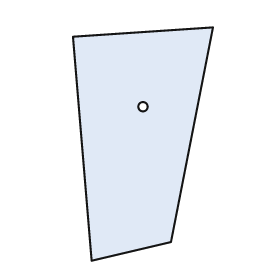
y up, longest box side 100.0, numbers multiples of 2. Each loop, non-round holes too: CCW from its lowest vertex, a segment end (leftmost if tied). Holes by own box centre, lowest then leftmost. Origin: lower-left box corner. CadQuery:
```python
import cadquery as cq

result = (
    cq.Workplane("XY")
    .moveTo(8.0, 0.0)
    .lineTo(42.0, 8.0)
    .lineTo(60.0, 100.0)
    .lineTo(0.0, 96.0)
    .close()
    .moveTo(30.0, 66.0)
    .circle(2.0)
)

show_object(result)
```